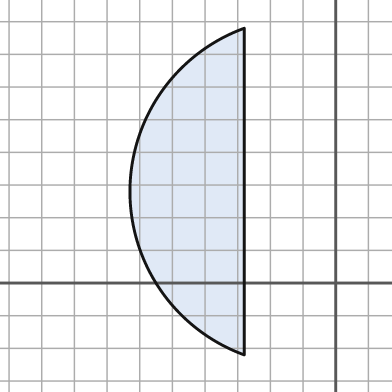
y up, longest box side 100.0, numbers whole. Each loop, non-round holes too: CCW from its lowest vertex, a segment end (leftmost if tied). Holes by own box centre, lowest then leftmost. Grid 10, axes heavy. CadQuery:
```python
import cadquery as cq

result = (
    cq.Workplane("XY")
    .moveTo(-28.0, -22.0)
    .lineTo(-28.0, 78.0)
    .threePointArc((-63.0, 28.0), (-28.0, -22.0))
    .close()
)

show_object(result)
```